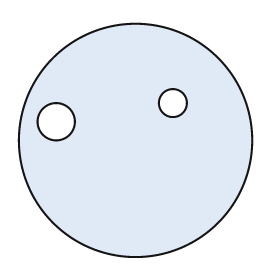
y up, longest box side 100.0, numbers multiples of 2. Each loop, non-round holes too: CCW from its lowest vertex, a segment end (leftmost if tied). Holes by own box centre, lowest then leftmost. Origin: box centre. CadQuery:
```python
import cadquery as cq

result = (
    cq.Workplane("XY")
    .moveTo(0.0, 0.0)
    .circle(50.0)
    .moveTo(-34.0, 8.0)
    .circle(8.0)
    .moveTo(16.0, 16.0)
    .circle(6.0)
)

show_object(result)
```